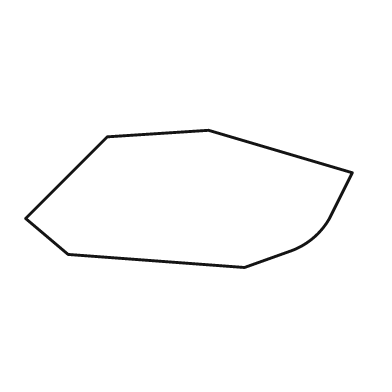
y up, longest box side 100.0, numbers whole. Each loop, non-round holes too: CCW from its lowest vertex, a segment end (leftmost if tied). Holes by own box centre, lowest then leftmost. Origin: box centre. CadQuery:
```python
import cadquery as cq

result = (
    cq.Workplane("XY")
    .moveTo(17.0, -21.0)
    .lineTo(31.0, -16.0)
    .threePointArc((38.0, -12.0), (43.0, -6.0))
    .lineTo(50.0, 8.0)
    .lineTo(6.0, 21.0)
    .lineTo(-25.0, 19.0)
    .lineTo(-50.0, -6.0)
    .lineTo(-37.0, -17.0)
    .close()
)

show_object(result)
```